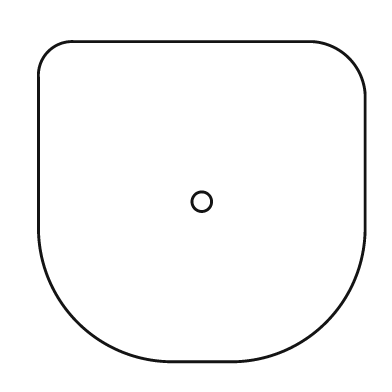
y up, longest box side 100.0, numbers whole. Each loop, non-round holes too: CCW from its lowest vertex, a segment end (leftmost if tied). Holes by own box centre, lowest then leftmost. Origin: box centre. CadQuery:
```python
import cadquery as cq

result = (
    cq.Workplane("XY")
    .moveTo(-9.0, -49.0)
    .lineTo(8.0, -49.0)
    .threePointArc((38.0, -37.0), (50.0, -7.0))
    .lineTo(50.0, 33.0)
    .threePointArc((45.0, 44.0), (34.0, 49.0))
    .lineTo(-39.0, 49.0)
    .threePointArc((-47.0, 46.0), (-50.0, 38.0))
    .lineTo(-50.0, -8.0)
    .threePointArc((-38.0, -37.0), (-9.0, -49.0))
    .close()
    .moveTo(0.0, 0.0)
    .circle(3.0)
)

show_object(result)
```